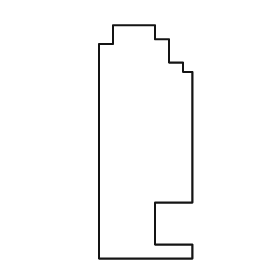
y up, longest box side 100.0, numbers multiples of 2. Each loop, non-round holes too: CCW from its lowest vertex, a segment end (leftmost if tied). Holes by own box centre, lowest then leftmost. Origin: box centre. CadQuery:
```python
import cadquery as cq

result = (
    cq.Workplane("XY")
    .moveTo(-20.0, -50.0)
    .lineTo(20.0, -50.0)
    .lineTo(20.0, -44.0)
    .lineTo(4.0, -44.0)
    .lineTo(4.0, -26.0)
    .lineTo(20.0, -26.0)
    .lineTo(20.0, 30.0)
    .lineTo(16.0, 30.0)
    .lineTo(16.0, 34.0)
    .lineTo(10.0, 34.0)
    .lineTo(10.0, 44.0)
    .lineTo(4.0, 44.0)
    .lineTo(4.0, 50.0)
    .lineTo(-14.0, 50.0)
    .lineTo(-14.0, 42.0)
    .lineTo(-20.0, 42.0)
    .close()
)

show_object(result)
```